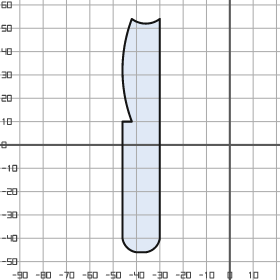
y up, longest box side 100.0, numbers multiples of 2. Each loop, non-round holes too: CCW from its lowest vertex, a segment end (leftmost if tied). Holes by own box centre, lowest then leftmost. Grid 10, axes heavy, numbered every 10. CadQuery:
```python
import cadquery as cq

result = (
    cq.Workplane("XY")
    .moveTo(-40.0, -46.0)
    .lineTo(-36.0, -46.0)
    .threePointArc((-32.0, -44.0), (-30.0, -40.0))
    .lineTo(-30.0, 54.0)
    .threePointArc((-36.0, 52.0), (-42.0, 54.0))
    .threePointArc((-46.0, 32.0), (-42.0, 10.0))
    .lineTo(-46.0, 10.0)
    .lineTo(-46.0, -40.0)
    .threePointArc((-44.0, -44.0), (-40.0, -46.0))
    .close()
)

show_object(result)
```